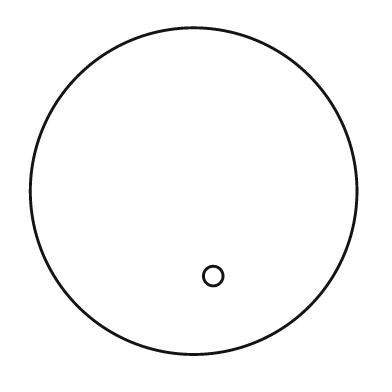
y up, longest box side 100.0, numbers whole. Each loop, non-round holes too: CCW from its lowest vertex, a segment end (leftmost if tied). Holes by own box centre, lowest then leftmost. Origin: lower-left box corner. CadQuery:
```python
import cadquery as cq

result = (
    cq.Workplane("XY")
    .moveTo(50.0, 50.0)
    .circle(50.0)
    .moveTo(56.0, 24.0)
    .circle(3.0)
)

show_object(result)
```